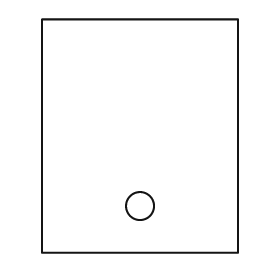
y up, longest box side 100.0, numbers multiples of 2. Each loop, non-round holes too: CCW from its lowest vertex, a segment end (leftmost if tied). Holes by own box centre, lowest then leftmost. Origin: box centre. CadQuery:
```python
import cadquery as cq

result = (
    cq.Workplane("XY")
    .moveTo(-42.0, -50.0)
    .lineTo(42.0, -50.0)
    .lineTo(42.0, 50.0)
    .lineTo(-42.0, 50.0)
    .close()
    .moveTo(0.0, -30.0)
    .circle(6.0)
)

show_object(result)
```